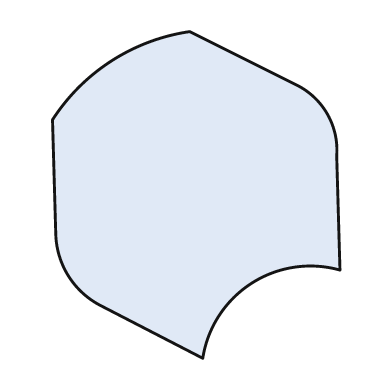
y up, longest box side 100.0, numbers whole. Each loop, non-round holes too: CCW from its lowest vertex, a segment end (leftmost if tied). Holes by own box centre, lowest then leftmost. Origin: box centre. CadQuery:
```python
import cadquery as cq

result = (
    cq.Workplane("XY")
    .moveTo(2.0, -50.0)
    .threePointArc((17.0, -27.0), (44.0, -23.0))
    .lineTo(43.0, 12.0)
    .threePointArc((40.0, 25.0), (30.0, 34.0))
    .lineTo(-2.0, 50.0)
    .threePointArc((-26.0, 41.0), (-44.0, 23.0))
    .lineTo(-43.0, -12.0)
    .threePointArc((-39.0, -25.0), (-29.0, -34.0))
    .close()
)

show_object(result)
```